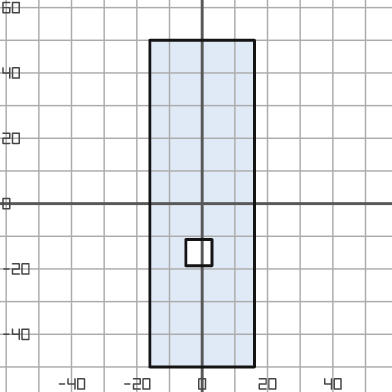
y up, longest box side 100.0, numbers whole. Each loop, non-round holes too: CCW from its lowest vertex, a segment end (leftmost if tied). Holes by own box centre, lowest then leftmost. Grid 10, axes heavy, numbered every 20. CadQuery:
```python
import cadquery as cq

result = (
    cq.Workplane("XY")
    .moveTo(-16.0, -50.0)
    .lineTo(16.0, -50.0)
    .lineTo(16.0, 50.0)
    .lineTo(-16.0, 50.0)
    .close()
    .moveTo(-5.0, -19.0)
    .lineTo(3.0, -19.0)
    .lineTo(3.0, -11.0)
    .lineTo(-5.0, -11.0)
    .close()
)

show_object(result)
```